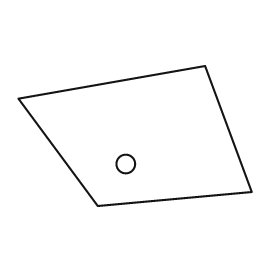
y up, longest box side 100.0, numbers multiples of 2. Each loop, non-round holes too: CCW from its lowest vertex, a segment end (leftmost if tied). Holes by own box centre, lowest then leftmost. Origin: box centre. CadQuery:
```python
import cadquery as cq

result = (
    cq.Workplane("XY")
    .moveTo(-16.0, -30.0)
    .lineTo(50.0, -24.0)
    .lineTo(30.0, 30.0)
    .lineTo(-50.0, 16.0)
    .close()
    .moveTo(-4.0, -12.0)
    .circle(4.0)
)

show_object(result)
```